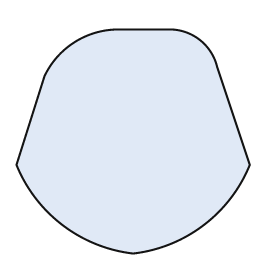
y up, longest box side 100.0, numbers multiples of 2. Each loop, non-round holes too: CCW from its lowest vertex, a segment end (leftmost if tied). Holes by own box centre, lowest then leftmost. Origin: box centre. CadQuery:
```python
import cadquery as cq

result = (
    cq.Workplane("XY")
    .moveTo(0.0, -48.0)
    .threePointArc((30.0, -36.0), (50.0, -10.0))
    .lineTo(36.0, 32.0)
    .threePointArc((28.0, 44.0), (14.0, 48.0))
    .lineTo(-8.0, 48.0)
    .threePointArc((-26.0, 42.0), (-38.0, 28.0))
    .lineTo(-50.0, -10.0)
    .threePointArc((-30.0, -36.0), (0.0, -48.0))
    .close()
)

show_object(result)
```